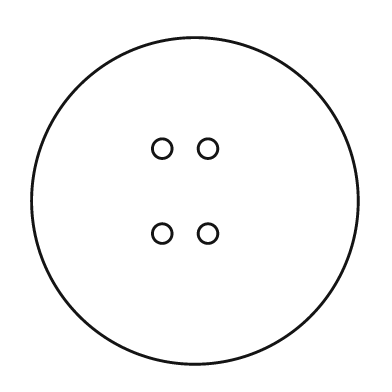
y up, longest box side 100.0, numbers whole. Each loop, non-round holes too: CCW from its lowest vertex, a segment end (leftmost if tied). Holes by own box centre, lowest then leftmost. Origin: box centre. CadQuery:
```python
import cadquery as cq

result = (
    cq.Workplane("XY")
    .moveTo(0.0, 0.0)
    .circle(50.0)
    .moveTo(-10.0, -10.0)
    .circle(3.0)
    .moveTo(4.0, -10.0)
    .circle(3.0)
    .moveTo(-10.0, 16.0)
    .circle(3.0)
    .moveTo(4.0, 16.0)
    .circle(3.0)
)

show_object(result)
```